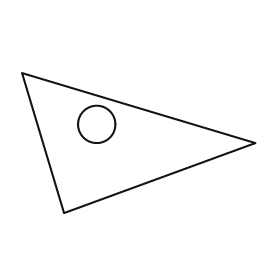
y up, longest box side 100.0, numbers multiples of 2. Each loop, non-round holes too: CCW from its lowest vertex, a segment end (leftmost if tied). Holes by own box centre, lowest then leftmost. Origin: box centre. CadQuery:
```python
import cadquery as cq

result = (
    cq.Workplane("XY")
    .moveTo(-32.0, -30.0)
    .lineTo(50.0, 0.0)
    .lineTo(-50.0, 30.0)
    .close()
    .moveTo(-18.0, 8.0)
    .circle(8.0)
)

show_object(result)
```